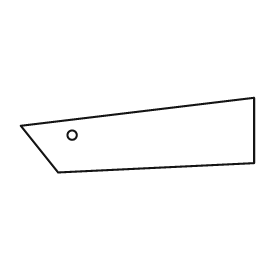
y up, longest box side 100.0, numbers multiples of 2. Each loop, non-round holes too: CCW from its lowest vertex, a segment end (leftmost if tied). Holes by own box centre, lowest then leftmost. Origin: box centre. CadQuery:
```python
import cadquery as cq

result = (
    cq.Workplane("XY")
    .moveTo(-34.0, -16.0)
    .lineTo(50.0, -12.0)
    .lineTo(50.0, 16.0)
    .lineTo(-50.0, 4.0)
    .close()
    .moveTo(-28.0, 0.0)
    .circle(2.0)
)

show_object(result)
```